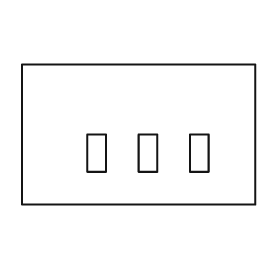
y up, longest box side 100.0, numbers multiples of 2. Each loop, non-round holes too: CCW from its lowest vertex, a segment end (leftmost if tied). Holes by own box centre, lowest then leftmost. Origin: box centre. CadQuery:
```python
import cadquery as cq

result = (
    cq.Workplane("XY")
    .moveTo(-50.0, -30.0)
    .lineTo(50.0, -30.0)
    .lineTo(50.0, 30.0)
    .lineTo(-50.0, 30.0)
    .close()
    .moveTo(-22.0, -16.0)
    .lineTo(-14.0, -16.0)
    .lineTo(-14.0, 0.0)
    .lineTo(-22.0, 0.0)
    .close()
    .moveTo(0.0, -16.0)
    .lineTo(8.0, -16.0)
    .lineTo(8.0, 0.0)
    .lineTo(0.0, 0.0)
    .close()
    .moveTo(22.0, -16.0)
    .lineTo(30.0, -16.0)
    .lineTo(30.0, 0.0)
    .lineTo(22.0, 0.0)
    .close()
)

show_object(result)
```